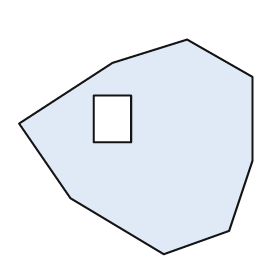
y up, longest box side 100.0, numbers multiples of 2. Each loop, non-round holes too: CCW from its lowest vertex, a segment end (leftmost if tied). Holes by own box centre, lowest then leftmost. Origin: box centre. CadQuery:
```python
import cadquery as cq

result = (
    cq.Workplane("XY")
    .moveTo(12.0, -46.0)
    .lineTo(40.0, -36.0)
    .lineTo(50.0, -6.0)
    .lineTo(50.0, 30.0)
    .lineTo(22.0, 46.0)
    .lineTo(-10.0, 36.0)
    .lineTo(-50.0, 10.0)
    .lineTo(-28.0, -22.0)
    .close()
    .moveTo(-18.0, 2.0)
    .lineTo(-2.0, 2.0)
    .lineTo(-2.0, 22.0)
    .lineTo(-18.0, 22.0)
    .close()
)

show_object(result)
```